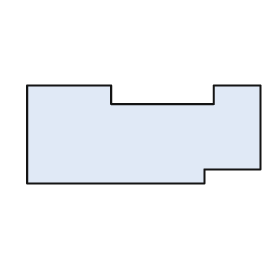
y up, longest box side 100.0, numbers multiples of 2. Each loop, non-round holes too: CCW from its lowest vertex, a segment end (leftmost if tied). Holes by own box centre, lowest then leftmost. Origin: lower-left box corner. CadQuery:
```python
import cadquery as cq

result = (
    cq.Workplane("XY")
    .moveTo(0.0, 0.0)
    .lineTo(76.0, 0.0)
    .lineTo(76.0, 6.0)
    .lineTo(100.0, 6.0)
    .lineTo(100.0, 42.0)
    .lineTo(80.0, 42.0)
    .lineTo(80.0, 34.0)
    .lineTo(36.0, 34.0)
    .lineTo(36.0, 42.0)
    .lineTo(0.0, 42.0)
    .close()
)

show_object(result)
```